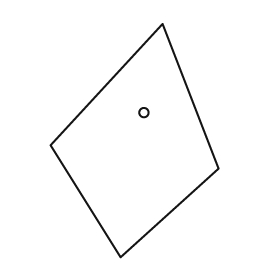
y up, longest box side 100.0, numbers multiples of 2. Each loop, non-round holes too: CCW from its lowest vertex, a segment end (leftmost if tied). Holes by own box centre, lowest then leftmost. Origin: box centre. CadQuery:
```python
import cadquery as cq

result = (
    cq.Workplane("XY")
    .moveTo(-6.0, -50.0)
    .lineTo(36.0, -12.0)
    .lineTo(12.0, 50.0)
    .lineTo(-36.0, -2.0)
    .close()
    .moveTo(4.0, 12.0)
    .circle(2.0)
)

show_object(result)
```